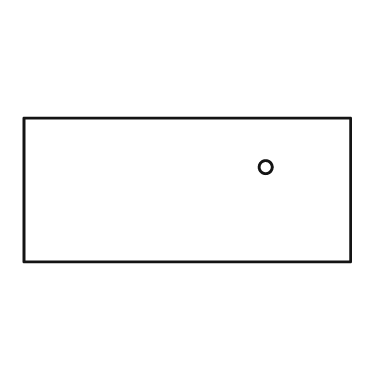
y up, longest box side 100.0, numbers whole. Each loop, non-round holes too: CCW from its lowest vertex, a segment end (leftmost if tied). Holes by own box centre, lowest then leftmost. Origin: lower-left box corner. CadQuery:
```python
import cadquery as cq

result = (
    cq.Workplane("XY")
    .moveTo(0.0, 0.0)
    .lineTo(100.0, 0.0)
    .lineTo(100.0, 44.0)
    .lineTo(0.0, 44.0)
    .close()
    .moveTo(74.0, 29.0)
    .circle(2.0)
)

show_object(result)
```